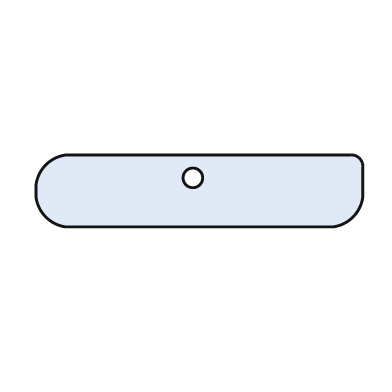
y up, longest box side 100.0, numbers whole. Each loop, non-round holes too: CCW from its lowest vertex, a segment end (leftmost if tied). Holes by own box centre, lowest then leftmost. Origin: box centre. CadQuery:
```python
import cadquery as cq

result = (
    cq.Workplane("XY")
    .moveTo(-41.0, -11.0)
    .lineTo(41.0, -11.0)
    .threePointArc((47.0, -8.0), (50.0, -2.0))
    .lineTo(50.0, 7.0)
    .threePointArc((49.0, 10.0), (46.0, 11.0))
    .lineTo(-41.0, 11.0)
    .threePointArc((-47.0, 8.0), (-50.0, 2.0))
    .lineTo(-50.0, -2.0)
    .threePointArc((-47.0, -8.0), (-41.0, -11.0))
    .close()
    .moveTo(-2.0, 4.0)
    .circle(3.0)
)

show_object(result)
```